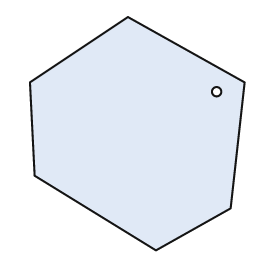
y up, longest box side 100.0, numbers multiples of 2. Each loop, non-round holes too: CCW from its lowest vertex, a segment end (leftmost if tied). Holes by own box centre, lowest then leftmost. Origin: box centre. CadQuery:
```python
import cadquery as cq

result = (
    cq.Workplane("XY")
    .moveTo(8.0, -50.0)
    .lineTo(40.0, -32.0)
    .lineTo(46.0, 22.0)
    .lineTo(-4.0, 50.0)
    .lineTo(-46.0, 22.0)
    .lineTo(-44.0, -18.0)
    .close()
    .moveTo(34.0, 18.0)
    .circle(2.0)
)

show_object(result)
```